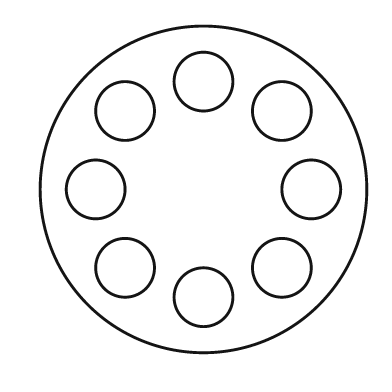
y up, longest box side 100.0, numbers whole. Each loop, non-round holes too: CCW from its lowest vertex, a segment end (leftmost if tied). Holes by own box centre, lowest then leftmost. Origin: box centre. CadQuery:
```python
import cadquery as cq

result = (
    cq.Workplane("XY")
    .moveTo(0.0, 0.0)
    .circle(50.0)
    .moveTo(0.0, -33.0)
    .circle(9.0)
    .moveTo(-24.0, -24.0)
    .circle(9.0)
    .moveTo(24.0, -24.0)
    .circle(9.0)
    .moveTo(-33.0, 0.0)
    .circle(9.0)
    .moveTo(33.0, 0.0)
    .circle(9.0)
    .moveTo(-24.0, 24.0)
    .circle(9.0)
    .moveTo(24.0, 24.0)
    .circle(9.0)
    .moveTo(0.0, 33.0)
    .circle(9.0)
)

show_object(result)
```